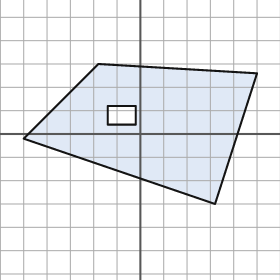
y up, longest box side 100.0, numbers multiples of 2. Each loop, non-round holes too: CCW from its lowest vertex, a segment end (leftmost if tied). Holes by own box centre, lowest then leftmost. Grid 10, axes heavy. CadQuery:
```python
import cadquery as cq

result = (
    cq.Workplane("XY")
    .moveTo(32.0, -30.0)
    .lineTo(50.0, 26.0)
    .lineTo(-18.0, 30.0)
    .lineTo(-50.0, -2.0)
    .close()
    .moveTo(-14.0, 4.0)
    .lineTo(-2.0, 4.0)
    .lineTo(-2.0, 12.0)
    .lineTo(-14.0, 12.0)
    .close()
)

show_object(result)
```